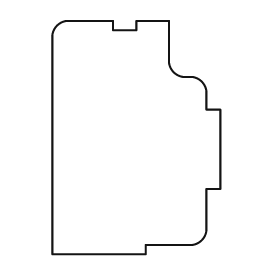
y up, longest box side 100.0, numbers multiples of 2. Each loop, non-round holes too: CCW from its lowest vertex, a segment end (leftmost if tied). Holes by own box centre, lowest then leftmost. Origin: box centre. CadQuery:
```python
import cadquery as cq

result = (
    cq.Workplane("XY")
    .moveTo(-36.0, -50.0)
    .lineTo(4.0, -50.0)
    .lineTo(4.0, -46.0)
    .lineTo(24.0, -46.0)
    .threePointArc((28.0, -44.0), (30.0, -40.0))
    .lineTo(30.0, -22.0)
    .lineTo(36.0, -22.0)
    .lineTo(36.0, 12.0)
    .lineTo(30.0, 12.0)
    .lineTo(30.0, 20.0)
    .threePointArc((28.0, 24.0), (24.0, 26.0))
    .lineTo(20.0, 26.0)
    .threePointArc((16.0, 28.0), (14.0, 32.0))
    .lineTo(14.0, 50.0)
    .lineTo(0.0, 50.0)
    .lineTo(0.0, 46.0)
    .lineTo(-10.0, 46.0)
    .lineTo(-10.0, 50.0)
    .lineTo(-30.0, 50.0)
    .threePointArc((-34.0, 48.0), (-36.0, 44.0))
    .close()
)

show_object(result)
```